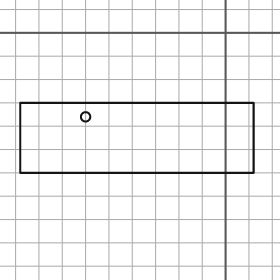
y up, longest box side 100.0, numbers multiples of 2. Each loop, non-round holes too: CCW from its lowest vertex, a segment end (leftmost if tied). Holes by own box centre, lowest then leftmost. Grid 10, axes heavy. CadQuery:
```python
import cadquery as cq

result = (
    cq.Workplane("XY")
    .moveTo(-88.0, -60.0)
    .lineTo(12.0, -60.0)
    .lineTo(12.0, -30.0)
    .lineTo(-88.0, -30.0)
    .close()
    .moveTo(-60.0, -36.0)
    .circle(2.0)
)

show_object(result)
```